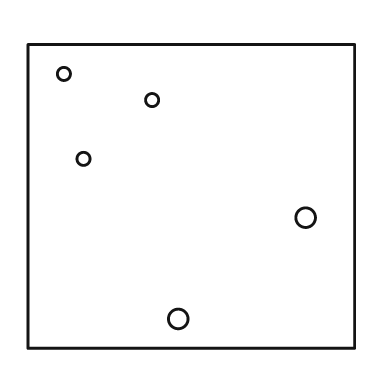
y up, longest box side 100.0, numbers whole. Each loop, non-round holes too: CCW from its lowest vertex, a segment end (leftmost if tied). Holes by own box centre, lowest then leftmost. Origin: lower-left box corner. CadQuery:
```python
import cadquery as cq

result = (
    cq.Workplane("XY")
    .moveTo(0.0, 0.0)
    .lineTo(100.0, 0.0)
    .lineTo(100.0, 93.0)
    .lineTo(0.0, 93.0)
    .close()
    .moveTo(46.0, 9.0)
    .circle(3.0)
    .moveTo(85.0, 40.0)
    .circle(3.0)
    .moveTo(17.0, 58.0)
    .circle(2.0)
    .moveTo(38.0, 76.0)
    .circle(2.0)
    .moveTo(11.0, 84.0)
    .circle(2.0)
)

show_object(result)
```